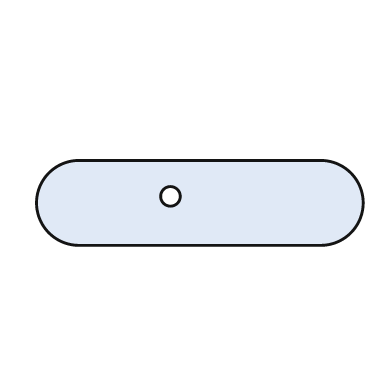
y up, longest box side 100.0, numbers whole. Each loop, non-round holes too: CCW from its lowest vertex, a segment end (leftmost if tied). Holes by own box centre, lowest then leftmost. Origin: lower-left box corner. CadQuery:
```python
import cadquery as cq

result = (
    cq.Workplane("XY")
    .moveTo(13.0, 0.0)
    .lineTo(87.0, 0.0)
    .threePointArc((100.0, 13.0), (87.0, 26.0))
    .lineTo(13.0, 26.0)
    .threePointArc((0.0, 13.0), (13.0, 0.0))
    .close()
    .moveTo(41.0, 15.0)
    .circle(3.0)
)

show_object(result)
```